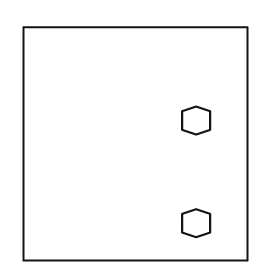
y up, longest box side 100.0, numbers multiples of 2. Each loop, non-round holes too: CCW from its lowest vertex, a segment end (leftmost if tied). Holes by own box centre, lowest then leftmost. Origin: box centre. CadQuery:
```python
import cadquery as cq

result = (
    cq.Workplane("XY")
    .moveTo(-48.0, -50.0)
    .lineTo(48.0, -50.0)
    .lineTo(48.0, 50.0)
    .lineTo(-48.0, 50.0)
    .close()
    .moveTo(26.0, -40.0)
    .lineTo(32.0, -38.0)
    .lineTo(32.0, -30.0)
    .lineTo(26.0, -28.0)
    .lineTo(20.0, -30.0)
    .lineTo(20.0, -38.0)
    .close()
    .moveTo(26.0, 4.0)
    .lineTo(32.0, 6.0)
    .lineTo(32.0, 14.0)
    .lineTo(26.0, 16.0)
    .lineTo(20.0, 14.0)
    .lineTo(20.0, 6.0)
    .close()
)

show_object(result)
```